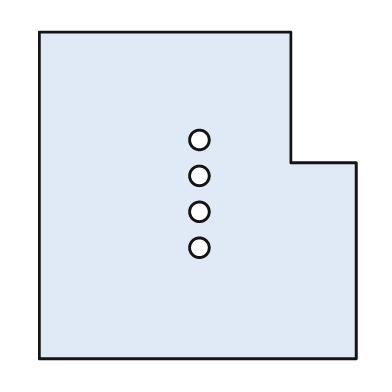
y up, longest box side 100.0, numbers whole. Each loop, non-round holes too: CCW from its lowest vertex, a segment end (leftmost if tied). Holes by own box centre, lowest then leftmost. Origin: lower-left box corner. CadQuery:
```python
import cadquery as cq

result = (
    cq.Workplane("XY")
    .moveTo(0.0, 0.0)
    .lineTo(97.0, 0.0)
    .lineTo(97.0, 60.0)
    .lineTo(77.0, 60.0)
    .lineTo(77.0, 100.0)
    .lineTo(0.0, 100.0)
    .close()
    .moveTo(49.0, 34.0)
    .circle(3.0)
    .moveTo(49.0, 45.0)
    .circle(3.0)
    .moveTo(49.0, 56.0)
    .circle(3.0)
    .moveTo(49.0, 67.0)
    .circle(3.0)
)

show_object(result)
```